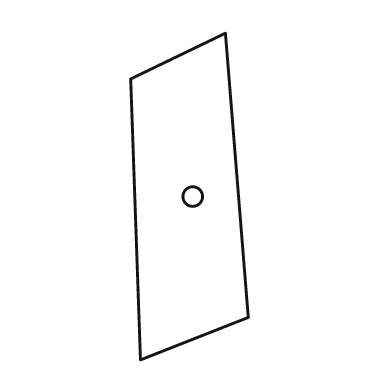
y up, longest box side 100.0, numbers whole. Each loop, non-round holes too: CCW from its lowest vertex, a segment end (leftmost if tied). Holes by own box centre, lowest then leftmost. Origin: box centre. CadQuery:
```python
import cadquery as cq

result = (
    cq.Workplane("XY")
    .moveTo(-15.0, -50.0)
    .lineTo(18.0, -37.0)
    .lineTo(11.0, 50.0)
    .lineTo(-18.0, 36.0)
    .close()
    .moveTo(1.0, 0.0)
    .circle(3.0)
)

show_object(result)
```